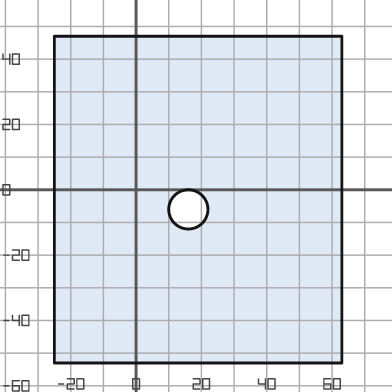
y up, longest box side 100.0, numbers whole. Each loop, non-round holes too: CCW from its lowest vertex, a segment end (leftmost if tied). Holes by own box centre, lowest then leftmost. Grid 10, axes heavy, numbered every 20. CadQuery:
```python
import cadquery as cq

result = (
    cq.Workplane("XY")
    .moveTo(-25.0, -53.0)
    .lineTo(63.0, -53.0)
    .lineTo(63.0, 47.0)
    .lineTo(-25.0, 47.0)
    .close()
    .moveTo(16.0, -6.0)
    .circle(6.0)
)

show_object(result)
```